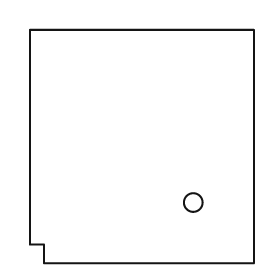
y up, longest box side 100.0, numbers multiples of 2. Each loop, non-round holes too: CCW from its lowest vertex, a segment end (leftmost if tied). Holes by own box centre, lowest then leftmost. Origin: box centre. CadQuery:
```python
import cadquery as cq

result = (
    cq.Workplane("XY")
    .moveTo(-42.0, -50.0)
    .lineTo(48.0, -50.0)
    .lineTo(48.0, 50.0)
    .lineTo(-48.0, 50.0)
    .lineTo(-48.0, -42.0)
    .lineTo(-42.0, -42.0)
    .close()
    .moveTo(22.0, -24.0)
    .circle(4.0)
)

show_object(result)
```